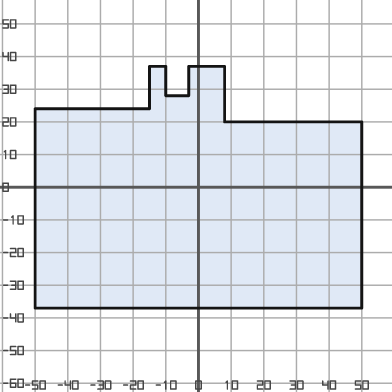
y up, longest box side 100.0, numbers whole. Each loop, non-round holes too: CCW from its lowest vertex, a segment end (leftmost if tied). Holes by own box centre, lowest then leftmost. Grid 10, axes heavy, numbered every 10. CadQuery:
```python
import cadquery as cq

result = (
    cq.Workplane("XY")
    .moveTo(-50.0, -37.0)
    .lineTo(50.0, -37.0)
    .lineTo(50.0, 20.0)
    .lineTo(8.0, 20.0)
    .lineTo(8.0, 37.0)
    .lineTo(-3.0, 37.0)
    .lineTo(-3.0, 28.0)
    .lineTo(-10.0, 28.0)
    .lineTo(-10.0, 37.0)
    .lineTo(-15.0, 37.0)
    .lineTo(-15.0, 24.0)
    .lineTo(-50.0, 24.0)
    .close()
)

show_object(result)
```